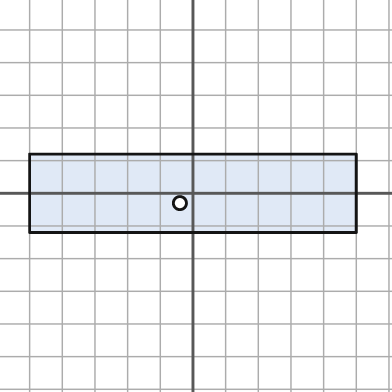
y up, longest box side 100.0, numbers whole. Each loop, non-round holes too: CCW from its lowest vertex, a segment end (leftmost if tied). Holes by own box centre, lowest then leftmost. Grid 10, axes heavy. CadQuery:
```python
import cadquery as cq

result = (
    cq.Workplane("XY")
    .moveTo(-50.0, -12.0)
    .lineTo(50.0, -12.0)
    .lineTo(50.0, 12.0)
    .lineTo(-50.0, 12.0)
    .close()
    .moveTo(-4.0, -3.0)
    .circle(2.0)
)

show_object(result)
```